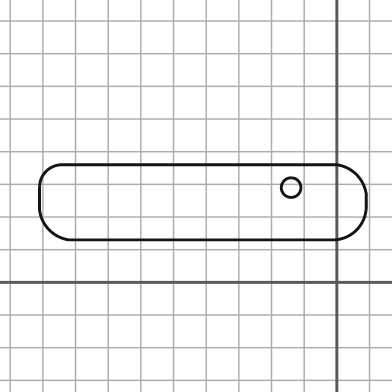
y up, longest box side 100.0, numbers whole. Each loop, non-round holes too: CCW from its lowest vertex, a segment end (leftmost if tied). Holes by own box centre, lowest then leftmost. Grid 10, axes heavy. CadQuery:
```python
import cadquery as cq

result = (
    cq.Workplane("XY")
    .moveTo(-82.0, 13.0)
    .lineTo(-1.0, 13.0)
    .threePointArc((6.0, 16.0), (9.0, 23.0))
    .lineTo(9.0, 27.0)
    .threePointArc((6.0, 33.0), (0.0, 36.0))
    .lineTo(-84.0, 36.0)
    .threePointArc((-89.0, 34.0), (-91.0, 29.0))
    .lineTo(-91.0, 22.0)
    .threePointArc((-88.0, 16.0), (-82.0, 13.0))
    .close()
    .moveTo(-14.0, 29.0)
    .circle(3.0)
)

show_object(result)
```